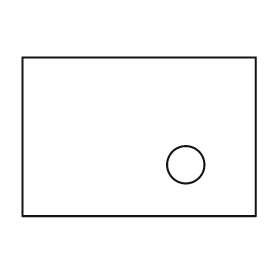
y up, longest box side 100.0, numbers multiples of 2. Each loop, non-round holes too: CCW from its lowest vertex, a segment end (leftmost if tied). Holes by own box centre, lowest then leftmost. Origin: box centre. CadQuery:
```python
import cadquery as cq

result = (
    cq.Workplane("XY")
    .moveTo(-50.0, -34.0)
    .lineTo(50.0, -34.0)
    .lineTo(50.0, 34.0)
    .lineTo(-50.0, 34.0)
    .close()
    .moveTo(20.0, -12.0)
    .circle(8.0)
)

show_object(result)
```